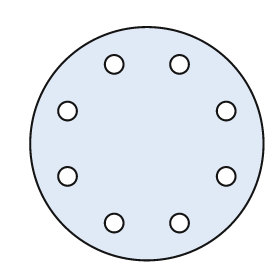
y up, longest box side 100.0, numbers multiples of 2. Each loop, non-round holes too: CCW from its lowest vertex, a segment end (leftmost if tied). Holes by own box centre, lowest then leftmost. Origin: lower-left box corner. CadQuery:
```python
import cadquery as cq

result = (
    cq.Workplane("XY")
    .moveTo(50.0, 50.0)
    .circle(50.0)
    .moveTo(36.0, 16.0)
    .circle(4.0)
    .moveTo(64.0, 16.0)
    .circle(4.0)
    .moveTo(16.0, 36.0)
    .circle(4.0)
    .moveTo(84.0, 36.0)
    .circle(4.0)
    .moveTo(16.0, 64.0)
    .circle(4.0)
    .moveTo(84.0, 64.0)
    .circle(4.0)
    .moveTo(36.0, 84.0)
    .circle(4.0)
    .moveTo(64.0, 84.0)
    .circle(4.0)
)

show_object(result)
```